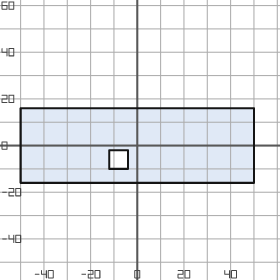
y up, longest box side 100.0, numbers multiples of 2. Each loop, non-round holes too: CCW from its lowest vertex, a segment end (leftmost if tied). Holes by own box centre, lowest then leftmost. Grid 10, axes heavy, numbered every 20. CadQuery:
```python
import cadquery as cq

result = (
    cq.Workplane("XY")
    .moveTo(-50.0, -16.0)
    .lineTo(50.0, -16.0)
    .lineTo(50.0, 16.0)
    .lineTo(-50.0, 16.0)
    .close()
    .moveTo(-12.0, -10.0)
    .lineTo(-4.0, -10.0)
    .lineTo(-4.0, -2.0)
    .lineTo(-12.0, -2.0)
    .close()
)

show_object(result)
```